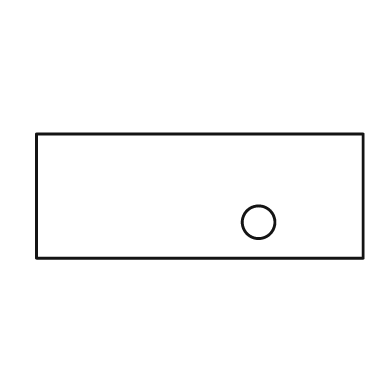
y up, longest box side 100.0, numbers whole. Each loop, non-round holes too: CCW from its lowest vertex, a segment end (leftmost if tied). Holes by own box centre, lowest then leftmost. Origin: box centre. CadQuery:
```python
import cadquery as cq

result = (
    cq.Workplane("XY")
    .moveTo(-50.0, -19.0)
    .lineTo(50.0, -19.0)
    .lineTo(50.0, 19.0)
    .lineTo(-50.0, 19.0)
    .close()
    .moveTo(18.0, -8.0)
    .circle(5.0)
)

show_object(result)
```